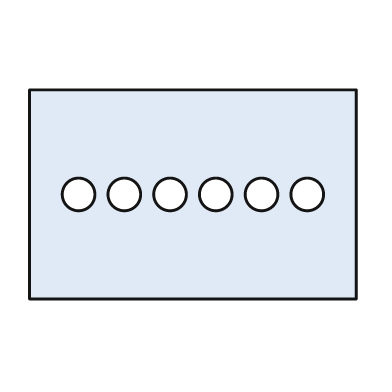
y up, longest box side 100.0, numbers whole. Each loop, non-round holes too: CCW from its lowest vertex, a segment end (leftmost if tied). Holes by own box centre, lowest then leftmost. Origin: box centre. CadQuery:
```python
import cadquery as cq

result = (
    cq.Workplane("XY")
    .moveTo(-50.0, -32.0)
    .lineTo(50.0, -32.0)
    .lineTo(50.0, 32.0)
    .lineTo(-50.0, 32.0)
    .close()
    .moveTo(-35.0, 0.0)
    .circle(5.0)
    .moveTo(-21.0, 0.0)
    .circle(5.0)
    .moveTo(-7.0, 0.0)
    .circle(5.0)
    .moveTo(7.0, 0.0)
    .circle(5.0)
    .moveTo(21.0, 0.0)
    .circle(5.0)
    .moveTo(35.0, 0.0)
    .circle(5.0)
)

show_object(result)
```